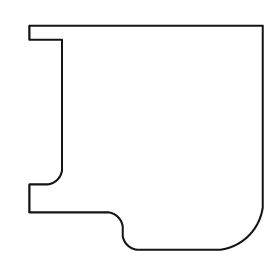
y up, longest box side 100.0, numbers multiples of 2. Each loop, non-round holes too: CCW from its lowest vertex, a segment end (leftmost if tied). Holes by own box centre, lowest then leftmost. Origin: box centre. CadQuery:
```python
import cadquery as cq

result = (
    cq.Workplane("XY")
    .moveTo(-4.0, -48.0)
    .lineTo(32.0, -48.0)
    .threePointArc((44.0, -42.0), (50.0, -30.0))
    .lineTo(50.0, 48.0)
    .lineTo(-50.0, 48.0)
    .lineTo(-50.0, 42.0)
    .lineTo(-36.0, 42.0)
    .lineTo(-36.0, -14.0)
    .threePointArc((-38.0, -18.0), (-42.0, -20.0))
    .lineTo(-50.0, -20.0)
    .lineTo(-50.0, -32.0)
    .lineTo(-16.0, -32.0)
    .threePointArc((-12.0, -34.0), (-10.0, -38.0))
    .lineTo(-10.0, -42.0)
    .threePointArc((-8.0, -46.0), (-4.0, -48.0))
    .close()
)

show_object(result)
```